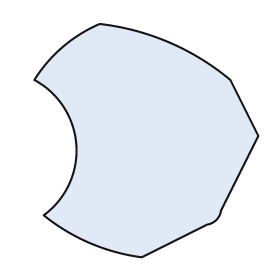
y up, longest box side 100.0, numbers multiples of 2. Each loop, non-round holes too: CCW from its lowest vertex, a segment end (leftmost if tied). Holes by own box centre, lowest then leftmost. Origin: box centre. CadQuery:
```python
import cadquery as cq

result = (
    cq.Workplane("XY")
    .moveTo(-2.0, -50.0)
    .lineTo(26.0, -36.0)
    .threePointArc((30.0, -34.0), (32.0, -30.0))
    .lineTo(48.0, 2.0)
    .lineTo(36.0, 26.0)
    .threePointArc((10.0, 42.0), (-20.0, 50.0))
    .threePointArc((-36.0, 40.0), (-48.0, 26.0))
    .threePointArc((-30.0, -2.0), (-44.0, -32.0))
    .threePointArc((-24.0, -44.0), (-2.0, -50.0))
    .close()
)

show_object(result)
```